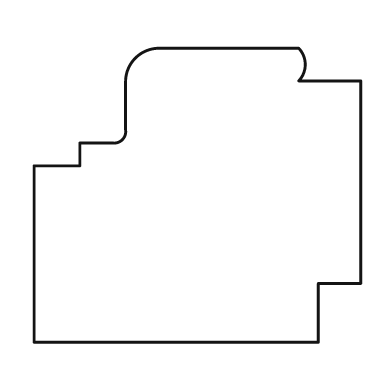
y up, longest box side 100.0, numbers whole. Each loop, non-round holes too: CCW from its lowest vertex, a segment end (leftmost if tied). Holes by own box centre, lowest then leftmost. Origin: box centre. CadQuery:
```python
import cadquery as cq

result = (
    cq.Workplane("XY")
    .moveTo(-50.0, -45.0)
    .lineTo(37.0, -45.0)
    .lineTo(37.0, -27.0)
    .lineTo(50.0, -27.0)
    .lineTo(50.0, 35.0)
    .lineTo(31.0, 35.0)
    .threePointArc((33.0, 40.0), (31.0, 45.0))
    .lineTo(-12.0, 45.0)
    .threePointArc((-19.0, 42.0), (-22.0, 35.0))
    .lineTo(-22.0, 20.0)
    .threePointArc((-23.0, 17.0), (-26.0, 16.0))
    .lineTo(-36.0, 16.0)
    .lineTo(-36.0, 9.0)
    .lineTo(-50.0, 9.0)
    .close()
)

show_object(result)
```